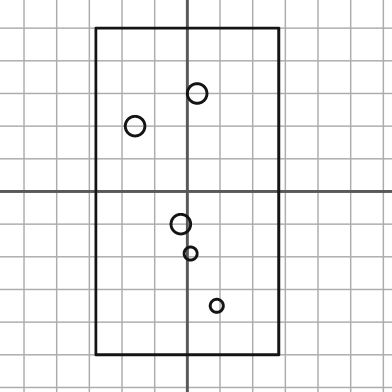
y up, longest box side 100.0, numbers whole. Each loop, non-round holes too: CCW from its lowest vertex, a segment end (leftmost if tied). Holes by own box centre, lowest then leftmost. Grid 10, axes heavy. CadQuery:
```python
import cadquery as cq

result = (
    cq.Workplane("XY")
    .moveTo(-28.0, -50.0)
    .lineTo(28.0, -50.0)
    .lineTo(28.0, 50.0)
    .lineTo(-28.0, 50.0)
    .close()
    .moveTo(9.0, -35.0)
    .circle(2.0)
    .moveTo(1.0, -19.0)
    .circle(2.0)
    .moveTo(-2.0, -10.0)
    .circle(3.0)
    .moveTo(-16.0, 20.0)
    .circle(3.0)
    .moveTo(3.0, 30.0)
    .circle(3.0)
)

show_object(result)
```